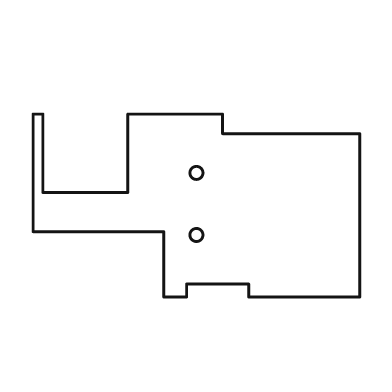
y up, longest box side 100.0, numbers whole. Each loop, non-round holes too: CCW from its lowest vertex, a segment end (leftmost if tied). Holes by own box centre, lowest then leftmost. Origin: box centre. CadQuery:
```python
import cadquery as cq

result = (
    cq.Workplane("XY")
    .moveTo(-10.0, -28.0)
    .lineTo(-3.0, -28.0)
    .lineTo(-3.0, -24.0)
    .lineTo(16.0, -24.0)
    .lineTo(16.0, -28.0)
    .lineTo(50.0, -28.0)
    .lineTo(50.0, 22.0)
    .lineTo(8.0, 22.0)
    .lineTo(8.0, 28.0)
    .lineTo(-21.0, 28.0)
    .lineTo(-21.0, 4.0)
    .lineTo(-47.0, 4.0)
    .lineTo(-47.0, 28.0)
    .lineTo(-50.0, 28.0)
    .lineTo(-50.0, -8.0)
    .lineTo(-10.0, -8.0)
    .close()
    .moveTo(0.0, -9.0)
    .circle(2.0)
    .moveTo(0.0, 10.0)
    .circle(2.0)
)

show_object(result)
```